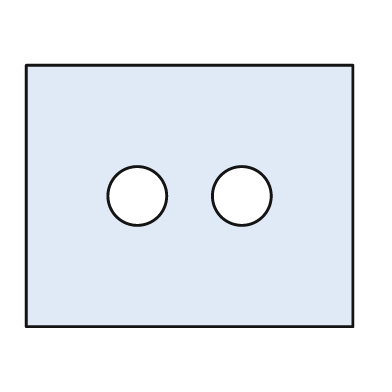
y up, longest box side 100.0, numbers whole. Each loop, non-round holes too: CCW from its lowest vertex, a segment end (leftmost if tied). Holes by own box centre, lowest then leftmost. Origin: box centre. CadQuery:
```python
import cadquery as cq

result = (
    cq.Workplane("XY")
    .moveTo(-50.0, -40.0)
    .lineTo(50.0, -40.0)
    .lineTo(50.0, 40.0)
    .lineTo(-50.0, 40.0)
    .close()
    .moveTo(-16.0, 0.0)
    .circle(9.0)
    .moveTo(16.0, 0.0)
    .circle(9.0)
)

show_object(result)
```